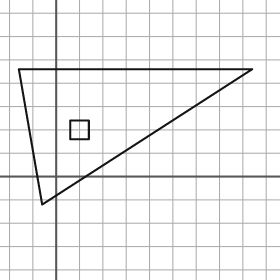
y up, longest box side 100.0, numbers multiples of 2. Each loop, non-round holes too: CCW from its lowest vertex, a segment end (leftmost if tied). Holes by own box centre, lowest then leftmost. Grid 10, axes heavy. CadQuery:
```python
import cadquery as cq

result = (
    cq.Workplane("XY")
    .moveTo(-6.0, -12.0)
    .lineTo(84.0, 46.0)
    .lineTo(-16.0, 46.0)
    .close()
    .moveTo(6.0, 16.0)
    .lineTo(14.0, 16.0)
    .lineTo(14.0, 24.0)
    .lineTo(6.0, 24.0)
    .close()
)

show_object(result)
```